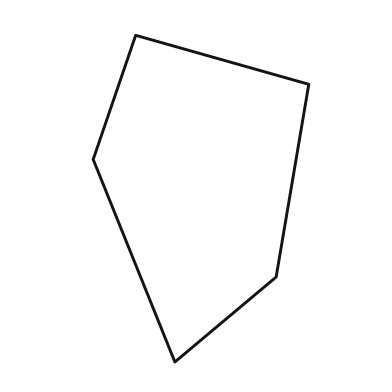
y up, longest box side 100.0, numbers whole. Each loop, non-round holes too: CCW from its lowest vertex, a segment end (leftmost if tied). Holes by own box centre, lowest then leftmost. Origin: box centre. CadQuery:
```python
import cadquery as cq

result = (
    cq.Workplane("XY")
    .moveTo(-8.0, -50.0)
    .lineTo(23.0, -24.0)
    .lineTo(33.0, 35.0)
    .lineTo(-20.0, 50.0)
    .lineTo(-33.0, 12.0)
    .close()
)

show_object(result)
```